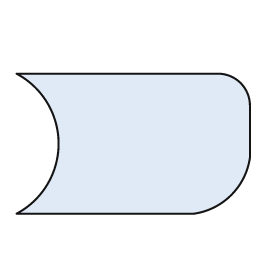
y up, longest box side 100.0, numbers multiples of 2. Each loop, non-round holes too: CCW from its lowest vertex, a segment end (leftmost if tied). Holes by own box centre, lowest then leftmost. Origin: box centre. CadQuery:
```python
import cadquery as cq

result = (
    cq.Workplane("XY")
    .moveTo(-50.0, -30.0)
    .lineTo(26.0, -30.0)
    .threePointArc((42.0, -22.0), (50.0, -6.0))
    .lineTo(50.0, 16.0)
    .threePointArc((46.0, 26.0), (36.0, 30.0))
    .lineTo(-50.0, 30.0)
    .threePointArc((-32.0, 0.0), (-50.0, -30.0))
    .close()
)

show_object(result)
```